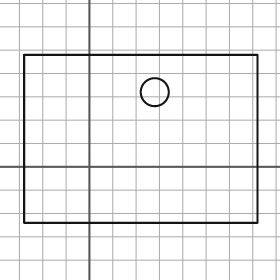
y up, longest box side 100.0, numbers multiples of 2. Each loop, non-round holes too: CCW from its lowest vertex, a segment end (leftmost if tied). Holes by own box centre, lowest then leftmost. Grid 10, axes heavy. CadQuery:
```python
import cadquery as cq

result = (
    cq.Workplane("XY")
    .moveTo(-28.0, -24.0)
    .lineTo(72.0, -24.0)
    .lineTo(72.0, 48.0)
    .lineTo(-28.0, 48.0)
    .close()
    .moveTo(28.0, 32.0)
    .circle(6.0)
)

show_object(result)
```